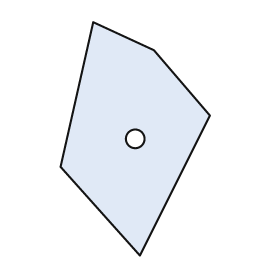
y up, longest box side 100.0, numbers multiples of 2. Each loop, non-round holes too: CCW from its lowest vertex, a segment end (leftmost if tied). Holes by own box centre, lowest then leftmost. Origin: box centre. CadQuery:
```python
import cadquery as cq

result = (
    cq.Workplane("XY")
    .moveTo(2.0, -50.0)
    .lineTo(32.0, 10.0)
    .lineTo(8.0, 38.0)
    .lineTo(-18.0, 50.0)
    .lineTo(-32.0, -12.0)
    .close()
    .moveTo(0.0, 0.0)
    .circle(4.0)
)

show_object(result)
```